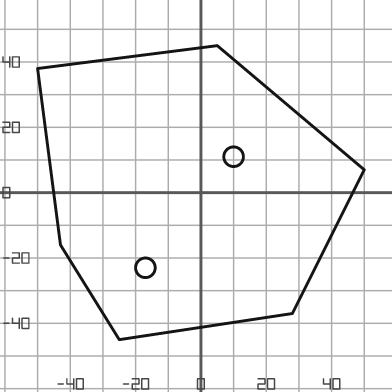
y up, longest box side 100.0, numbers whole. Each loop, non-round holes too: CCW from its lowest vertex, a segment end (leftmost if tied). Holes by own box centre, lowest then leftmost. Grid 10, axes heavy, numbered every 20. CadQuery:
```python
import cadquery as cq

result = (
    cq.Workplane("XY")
    .moveTo(-25.0, -45.0)
    .lineTo(28.0, -37.0)
    .lineTo(50.0, 7.0)
    .lineTo(5.0, 45.0)
    .lineTo(-50.0, 38.0)
    .lineTo(-43.0, -16.0)
    .close()
    .moveTo(-17.0, -23.0)
    .circle(3.0)
    .moveTo(10.0, 11.0)
    .circle(3.0)
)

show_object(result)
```